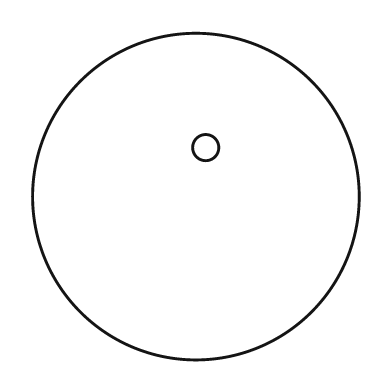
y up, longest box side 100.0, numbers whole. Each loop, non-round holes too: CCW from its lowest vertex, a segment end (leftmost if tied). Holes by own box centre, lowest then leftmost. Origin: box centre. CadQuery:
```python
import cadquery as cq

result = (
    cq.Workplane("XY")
    .moveTo(0.0, 0.0)
    .circle(50.0)
    .moveTo(3.0, 15.0)
    .circle(4.0)
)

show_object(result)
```